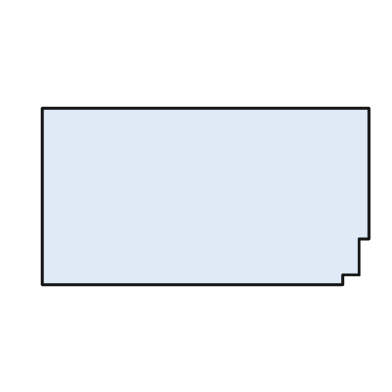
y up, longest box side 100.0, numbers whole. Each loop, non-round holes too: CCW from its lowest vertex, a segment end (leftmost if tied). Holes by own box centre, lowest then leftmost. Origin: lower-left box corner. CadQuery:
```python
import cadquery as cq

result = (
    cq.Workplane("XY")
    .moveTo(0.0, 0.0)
    .lineTo(92.0, 0.0)
    .lineTo(92.0, 3.0)
    .lineTo(97.0, 3.0)
    .lineTo(97.0, 14.0)
    .lineTo(100.0, 14.0)
    .lineTo(100.0, 54.0)
    .lineTo(0.0, 54.0)
    .close()
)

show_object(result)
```